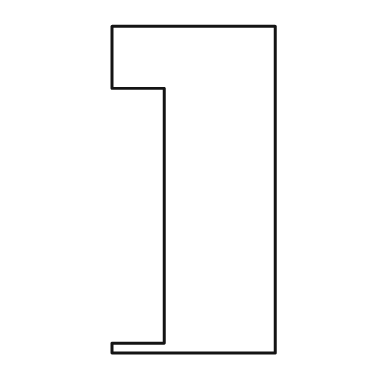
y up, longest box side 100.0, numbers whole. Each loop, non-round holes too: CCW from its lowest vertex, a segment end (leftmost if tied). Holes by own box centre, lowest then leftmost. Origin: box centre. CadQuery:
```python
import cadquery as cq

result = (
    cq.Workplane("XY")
    .moveTo(-25.0, -50.0)
    .lineTo(25.0, -50.0)
    .lineTo(25.0, 50.0)
    .lineTo(-25.0, 50.0)
    .lineTo(-25.0, 31.0)
    .lineTo(-9.0, 31.0)
    .lineTo(-9.0, -47.0)
    .lineTo(-25.0, -47.0)
    .close()
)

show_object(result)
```